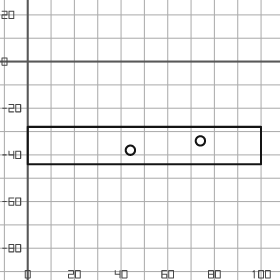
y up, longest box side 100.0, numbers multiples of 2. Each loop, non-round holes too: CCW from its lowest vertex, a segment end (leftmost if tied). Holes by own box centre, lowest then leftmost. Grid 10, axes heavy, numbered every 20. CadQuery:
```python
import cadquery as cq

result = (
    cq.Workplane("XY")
    .moveTo(0.0, -44.0)
    .lineTo(100.0, -44.0)
    .lineTo(100.0, -28.0)
    .lineTo(0.0, -28.0)
    .close()
    .moveTo(44.0, -38.0)
    .circle(2.0)
    .moveTo(74.0, -34.0)
    .circle(2.0)
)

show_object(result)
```